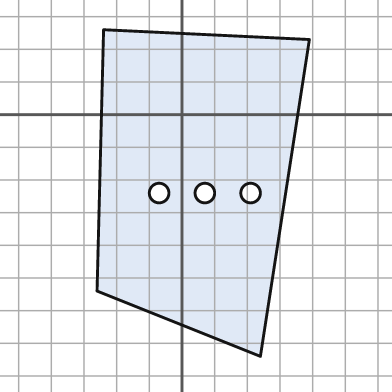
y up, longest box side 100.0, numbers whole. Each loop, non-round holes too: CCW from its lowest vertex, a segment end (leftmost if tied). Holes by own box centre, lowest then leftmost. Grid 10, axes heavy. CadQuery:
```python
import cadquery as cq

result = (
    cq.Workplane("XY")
    .moveTo(24.0, -74.0)
    .lineTo(39.0, 23.0)
    .lineTo(-24.0, 26.0)
    .lineTo(-26.0, -54.0)
    .close()
    .moveTo(-7.0, -24.0)
    .circle(3.0)
    .moveTo(7.0, -24.0)
    .circle(3.0)
    .moveTo(21.0, -24.0)
    .circle(3.0)
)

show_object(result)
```